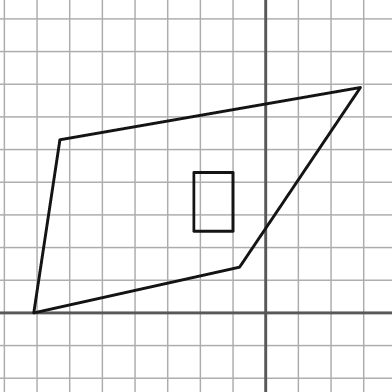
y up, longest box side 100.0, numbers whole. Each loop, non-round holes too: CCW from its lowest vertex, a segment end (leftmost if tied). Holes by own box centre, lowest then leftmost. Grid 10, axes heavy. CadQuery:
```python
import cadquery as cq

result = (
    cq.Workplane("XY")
    .moveTo(-71.0, 0.0)
    .lineTo(-8.0, 14.0)
    .lineTo(29.0, 69.0)
    .lineTo(-63.0, 53.0)
    .close()
    .moveTo(-22.0, 25.0)
    .lineTo(-10.0, 25.0)
    .lineTo(-10.0, 43.0)
    .lineTo(-22.0, 43.0)
    .close()
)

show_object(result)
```